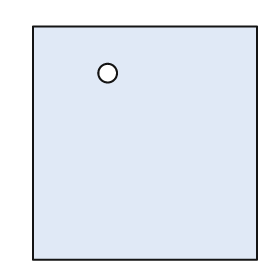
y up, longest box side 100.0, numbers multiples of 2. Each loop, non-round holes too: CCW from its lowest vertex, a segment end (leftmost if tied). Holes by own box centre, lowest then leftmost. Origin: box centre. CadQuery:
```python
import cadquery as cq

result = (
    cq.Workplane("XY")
    .moveTo(-48.0, -50.0)
    .lineTo(48.0, -50.0)
    .lineTo(48.0, 50.0)
    .lineTo(-48.0, 50.0)
    .close()
    .moveTo(-16.0, 30.0)
    .circle(4.0)
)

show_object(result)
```